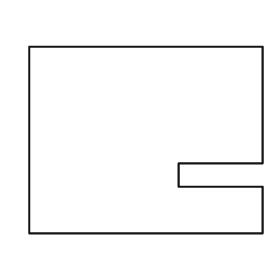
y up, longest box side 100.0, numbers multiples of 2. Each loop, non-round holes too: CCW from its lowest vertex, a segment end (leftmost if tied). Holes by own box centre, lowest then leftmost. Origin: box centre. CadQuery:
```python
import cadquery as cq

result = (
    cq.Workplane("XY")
    .moveTo(-50.0, -40.0)
    .lineTo(50.0, -40.0)
    .lineTo(50.0, -20.0)
    .lineTo(14.0, -20.0)
    .lineTo(14.0, -10.0)
    .lineTo(50.0, -10.0)
    .lineTo(50.0, 40.0)
    .lineTo(-50.0, 40.0)
    .close()
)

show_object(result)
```